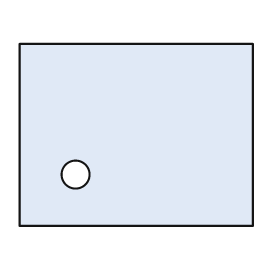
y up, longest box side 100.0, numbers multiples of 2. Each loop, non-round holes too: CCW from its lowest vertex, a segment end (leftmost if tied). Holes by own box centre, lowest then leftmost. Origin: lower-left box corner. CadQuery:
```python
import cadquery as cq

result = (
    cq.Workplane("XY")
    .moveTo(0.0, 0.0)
    .lineTo(100.0, 0.0)
    .lineTo(100.0, 78.0)
    .lineTo(0.0, 78.0)
    .close()
    .moveTo(24.0, 22.0)
    .circle(6.0)
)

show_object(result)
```